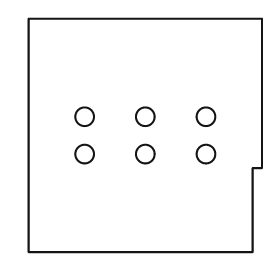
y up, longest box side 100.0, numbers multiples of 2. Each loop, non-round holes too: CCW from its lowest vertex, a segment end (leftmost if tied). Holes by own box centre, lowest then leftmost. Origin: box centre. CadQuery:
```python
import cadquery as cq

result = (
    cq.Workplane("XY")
    .moveTo(-50.0, -50.0)
    .lineTo(46.0, -50.0)
    .lineTo(46.0, -14.0)
    .lineTo(50.0, -14.0)
    .lineTo(50.0, 50.0)
    .lineTo(-50.0, 50.0)
    .close()
    .moveTo(-26.0, -8.0)
    .circle(4.0)
    .moveTo(0.0, -8.0)
    .circle(4.0)
    .moveTo(26.0, -8.0)
    .circle(4.0)
    .moveTo(-26.0, 8.0)
    .circle(4.0)
    .moveTo(0.0, 8.0)
    .circle(4.0)
    .moveTo(26.0, 8.0)
    .circle(4.0)
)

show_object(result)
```